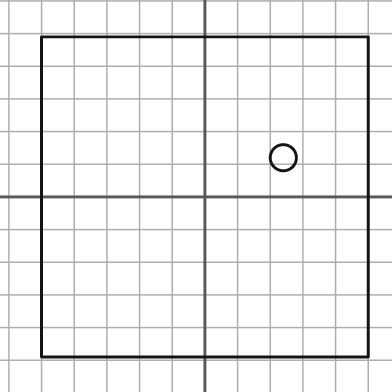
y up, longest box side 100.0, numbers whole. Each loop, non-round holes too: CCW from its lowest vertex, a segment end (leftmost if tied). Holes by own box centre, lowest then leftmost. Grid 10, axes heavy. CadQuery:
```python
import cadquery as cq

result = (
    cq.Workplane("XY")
    .moveTo(-50.0, -49.0)
    .lineTo(50.0, -49.0)
    .lineTo(50.0, 49.0)
    .lineTo(-50.0, 49.0)
    .close()
    .moveTo(24.0, 12.0)
    .circle(4.0)
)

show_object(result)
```